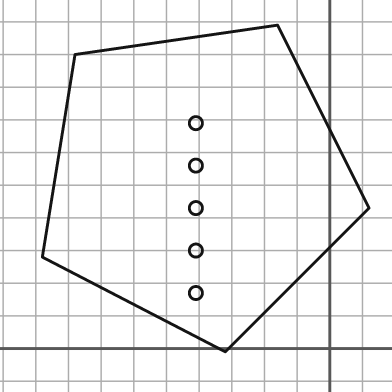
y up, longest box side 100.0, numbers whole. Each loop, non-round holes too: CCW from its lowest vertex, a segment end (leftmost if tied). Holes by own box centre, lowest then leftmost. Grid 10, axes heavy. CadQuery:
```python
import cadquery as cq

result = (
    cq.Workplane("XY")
    .moveTo(-32.0, -1.0)
    .lineTo(12.0, 43.0)
    .lineTo(-16.0, 99.0)
    .lineTo(-78.0, 90.0)
    .lineTo(-88.0, 28.0)
    .close()
    .moveTo(-41.0, 17.0)
    .circle(2.0)
    .moveTo(-41.0, 30.0)
    .circle(2.0)
    .moveTo(-41.0, 43.0)
    .circle(2.0)
    .moveTo(-41.0, 56.0)
    .circle(2.0)
    .moveTo(-41.0, 69.0)
    .circle(2.0)
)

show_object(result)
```